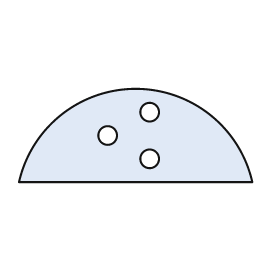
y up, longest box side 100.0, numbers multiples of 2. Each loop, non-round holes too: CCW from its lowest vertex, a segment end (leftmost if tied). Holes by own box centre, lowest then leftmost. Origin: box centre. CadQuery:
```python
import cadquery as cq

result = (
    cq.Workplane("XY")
    .moveTo(-50.0, -20.0)
    .lineTo(50.0, -20.0)
    .threePointArc((0.0, 20.0), (-50.0, -20.0))
    .close()
    .moveTo(6.0, -10.0)
    .circle(4.0)
    .moveTo(-12.0, 0.0)
    .circle(4.0)
    .moveTo(6.0, 10.0)
    .circle(4.0)
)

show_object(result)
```